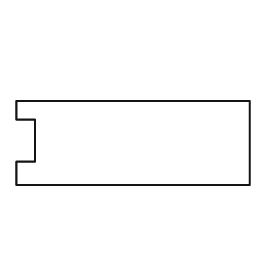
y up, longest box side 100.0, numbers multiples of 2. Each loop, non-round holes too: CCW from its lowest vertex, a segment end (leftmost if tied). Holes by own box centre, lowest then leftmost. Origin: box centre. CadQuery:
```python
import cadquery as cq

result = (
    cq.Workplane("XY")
    .moveTo(-50.0, -18.0)
    .lineTo(50.0, -18.0)
    .lineTo(50.0, 18.0)
    .lineTo(-50.0, 18.0)
    .lineTo(-50.0, 10.0)
    .lineTo(-42.0, 10.0)
    .lineTo(-42.0, -8.0)
    .lineTo(-50.0, -8.0)
    .close()
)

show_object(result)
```